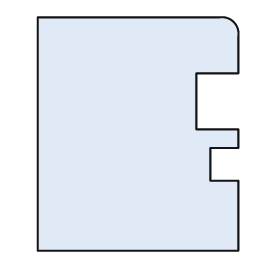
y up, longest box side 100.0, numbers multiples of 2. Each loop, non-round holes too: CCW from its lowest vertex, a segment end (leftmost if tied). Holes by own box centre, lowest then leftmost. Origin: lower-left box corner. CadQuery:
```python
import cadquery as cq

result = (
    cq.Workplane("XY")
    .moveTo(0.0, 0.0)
    .lineTo(86.0, 0.0)
    .lineTo(86.0, 30.0)
    .lineTo(74.0, 30.0)
    .lineTo(74.0, 44.0)
    .lineTo(86.0, 44.0)
    .lineTo(86.0, 52.0)
    .lineTo(68.0, 52.0)
    .lineTo(68.0, 76.0)
    .lineTo(86.0, 76.0)
    .lineTo(86.0, 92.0)
    .threePointArc((84.0, 98.0), (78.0, 100.0))
    .lineTo(0.0, 100.0)
    .close()
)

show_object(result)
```